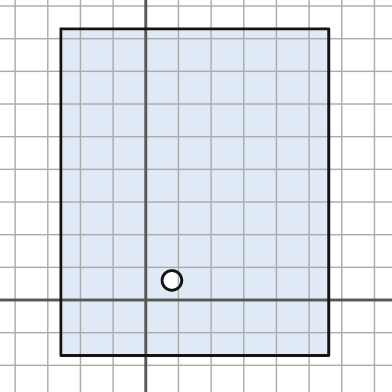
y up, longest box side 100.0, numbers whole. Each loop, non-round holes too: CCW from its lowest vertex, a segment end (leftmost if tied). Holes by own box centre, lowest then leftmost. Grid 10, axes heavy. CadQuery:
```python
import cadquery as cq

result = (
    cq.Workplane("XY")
    .moveTo(-26.0, -17.0)
    .lineTo(56.0, -17.0)
    .lineTo(56.0, 83.0)
    .lineTo(-26.0, 83.0)
    .close()
    .moveTo(8.0, 6.0)
    .circle(3.0)
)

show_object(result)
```